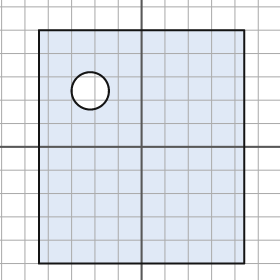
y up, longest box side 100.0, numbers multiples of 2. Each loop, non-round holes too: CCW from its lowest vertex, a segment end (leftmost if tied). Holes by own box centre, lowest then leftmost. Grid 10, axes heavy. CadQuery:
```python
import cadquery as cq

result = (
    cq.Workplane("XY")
    .moveTo(-44.0, -50.0)
    .lineTo(44.0, -50.0)
    .lineTo(44.0, 50.0)
    .lineTo(-44.0, 50.0)
    .close()
    .moveTo(-22.0, 24.0)
    .circle(8.0)
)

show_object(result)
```